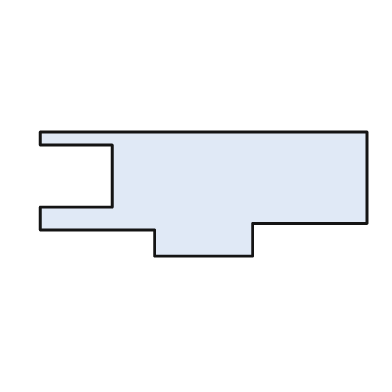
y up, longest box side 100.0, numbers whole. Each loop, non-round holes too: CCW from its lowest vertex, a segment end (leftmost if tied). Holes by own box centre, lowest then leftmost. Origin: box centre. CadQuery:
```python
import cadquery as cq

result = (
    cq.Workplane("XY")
    .moveTo(-15.0, -19.0)
    .lineTo(15.0, -19.0)
    .lineTo(15.0, -9.0)
    .lineTo(50.0, -9.0)
    .lineTo(50.0, 19.0)
    .lineTo(-50.0, 19.0)
    .lineTo(-50.0, 15.0)
    .lineTo(-28.0, 15.0)
    .lineTo(-28.0, -4.0)
    .lineTo(-50.0, -4.0)
    .lineTo(-50.0, -11.0)
    .lineTo(-15.0, -11.0)
    .close()
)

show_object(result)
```